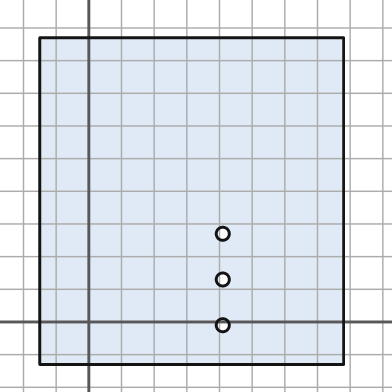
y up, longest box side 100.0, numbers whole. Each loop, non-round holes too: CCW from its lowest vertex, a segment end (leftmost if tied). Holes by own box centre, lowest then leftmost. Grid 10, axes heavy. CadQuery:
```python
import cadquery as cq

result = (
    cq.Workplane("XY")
    .moveTo(-15.0, -13.0)
    .lineTo(78.0, -13.0)
    .lineTo(78.0, 87.0)
    .lineTo(-15.0, 87.0)
    .close()
    .moveTo(41.0, -1.0)
    .circle(2.0)
    .moveTo(41.0, 13.0)
    .circle(2.0)
    .moveTo(41.0, 27.0)
    .circle(2.0)
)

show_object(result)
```